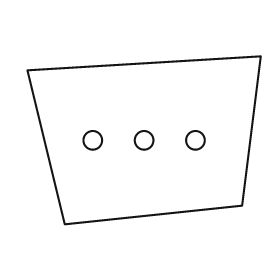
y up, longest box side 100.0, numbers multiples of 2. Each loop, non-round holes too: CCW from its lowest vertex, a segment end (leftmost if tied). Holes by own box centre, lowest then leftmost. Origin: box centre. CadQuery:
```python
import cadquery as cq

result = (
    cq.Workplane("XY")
    .moveTo(-34.0, -36.0)
    .lineTo(42.0, -28.0)
    .lineTo(50.0, 36.0)
    .lineTo(-50.0, 30.0)
    .close()
    .moveTo(-22.0, 0.0)
    .circle(4.0)
    .moveTo(0.0, 0.0)
    .circle(4.0)
    .moveTo(22.0, 0.0)
    .circle(4.0)
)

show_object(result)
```